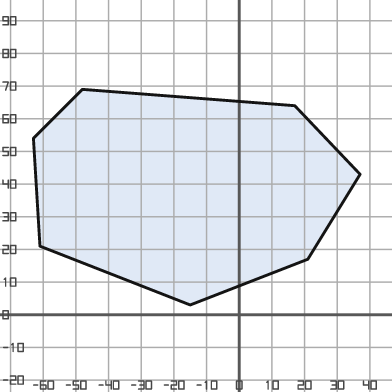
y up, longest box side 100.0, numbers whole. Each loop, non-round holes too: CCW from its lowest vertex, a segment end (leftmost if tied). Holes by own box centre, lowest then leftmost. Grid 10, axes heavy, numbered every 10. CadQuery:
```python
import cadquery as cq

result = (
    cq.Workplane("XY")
    .moveTo(-15.0, 3.0)
    .lineTo(21.0, 17.0)
    .lineTo(37.0, 43.0)
    .lineTo(17.0, 64.0)
    .lineTo(-48.0, 69.0)
    .lineTo(-63.0, 54.0)
    .lineTo(-61.0, 21.0)
    .close()
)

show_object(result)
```